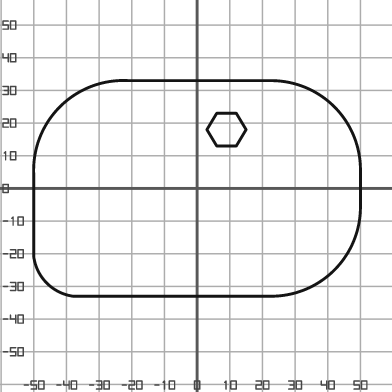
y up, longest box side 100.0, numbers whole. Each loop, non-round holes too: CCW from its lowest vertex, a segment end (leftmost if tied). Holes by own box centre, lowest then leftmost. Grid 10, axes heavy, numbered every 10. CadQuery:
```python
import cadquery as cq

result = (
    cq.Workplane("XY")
    .moveTo(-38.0, -33.0)
    .lineTo(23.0, -33.0)
    .threePointArc((42.0, -25.0), (50.0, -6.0))
    .lineTo(50.0, 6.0)
    .threePointArc((42.0, 25.0), (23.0, 33.0))
    .lineTo(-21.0, 33.0)
    .threePointArc((-42.0, 25.0), (-50.0, 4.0))
    .lineTo(-50.0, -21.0)
    .threePointArc((-46.0, -29.0), (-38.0, -33.0))
    .close()
    .moveTo(6.0, 13.0)
    .lineTo(12.0, 13.0)
    .lineTo(15.0, 18.0)
    .lineTo(12.0, 23.0)
    .lineTo(6.0, 23.0)
    .lineTo(3.0, 18.0)
    .close()
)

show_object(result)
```